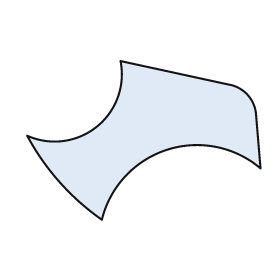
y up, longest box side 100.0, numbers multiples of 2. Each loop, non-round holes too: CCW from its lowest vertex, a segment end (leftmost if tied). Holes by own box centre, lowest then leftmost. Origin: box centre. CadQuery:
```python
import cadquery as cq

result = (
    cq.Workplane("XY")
    .moveTo(-18.0, -34.0)
    .threePointArc((10.0, -4.0), (50.0, -12.0))
    .lineTo(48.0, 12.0)
    .threePointArc((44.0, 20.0), (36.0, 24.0))
    .lineTo(-10.0, 34.0)
    .threePointArc((-20.0, 6.0), (-50.0, 2.0))
    .threePointArc((-36.0, -18.0), (-18.0, -34.0))
    .close()
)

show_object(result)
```